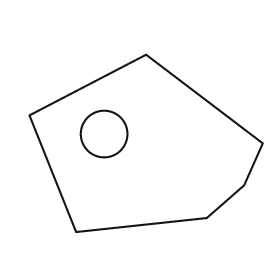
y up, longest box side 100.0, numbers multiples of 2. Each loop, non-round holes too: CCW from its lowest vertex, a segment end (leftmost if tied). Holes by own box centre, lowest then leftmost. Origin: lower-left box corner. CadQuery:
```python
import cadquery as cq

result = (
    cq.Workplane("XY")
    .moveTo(20.0, 0.0)
    .lineTo(76.0, 6.0)
    .lineTo(92.0, 20.0)
    .lineTo(100.0, 38.0)
    .lineTo(50.0, 76.0)
    .lineTo(0.0, 50.0)
    .close()
    .moveTo(32.0, 42.0)
    .circle(10.0)
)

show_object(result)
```